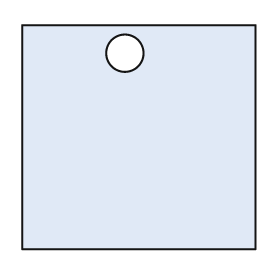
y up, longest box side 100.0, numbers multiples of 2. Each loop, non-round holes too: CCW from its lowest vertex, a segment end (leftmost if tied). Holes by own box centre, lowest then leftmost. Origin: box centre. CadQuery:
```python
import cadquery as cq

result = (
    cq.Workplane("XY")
    .moveTo(-50.0, -48.0)
    .lineTo(50.0, -48.0)
    .lineTo(50.0, 48.0)
    .lineTo(-50.0, 48.0)
    .close()
    .moveTo(-6.0, 36.0)
    .circle(8.0)
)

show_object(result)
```